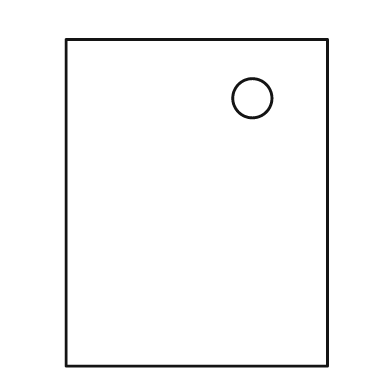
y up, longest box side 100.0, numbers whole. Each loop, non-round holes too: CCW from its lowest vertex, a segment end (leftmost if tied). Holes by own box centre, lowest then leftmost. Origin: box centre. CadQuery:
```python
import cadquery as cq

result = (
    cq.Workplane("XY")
    .moveTo(-40.0, -50.0)
    .lineTo(40.0, -50.0)
    .lineTo(40.0, 50.0)
    .lineTo(-40.0, 50.0)
    .close()
    .moveTo(17.0, 32.0)
    .circle(6.0)
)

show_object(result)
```